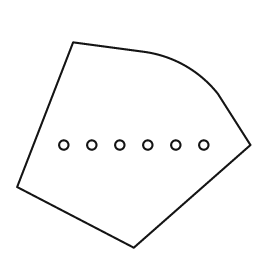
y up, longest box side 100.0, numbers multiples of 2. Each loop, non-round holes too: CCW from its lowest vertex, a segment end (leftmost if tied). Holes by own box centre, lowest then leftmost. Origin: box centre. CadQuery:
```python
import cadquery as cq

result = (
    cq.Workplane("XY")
    .moveTo(0.0, -44.0)
    .lineTo(50.0, 0.0)
    .lineTo(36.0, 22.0)
    .threePointArc((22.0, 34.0), (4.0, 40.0))
    .lineTo(-26.0, 44.0)
    .lineTo(-50.0, -18.0)
    .close()
    .moveTo(-30.0, 0.0)
    .circle(2.0)
    .moveTo(-18.0, 0.0)
    .circle(2.0)
    .moveTo(-6.0, 0.0)
    .circle(2.0)
    .moveTo(6.0, 0.0)
    .circle(2.0)
    .moveTo(18.0, 0.0)
    .circle(2.0)
    .moveTo(30.0, 0.0)
    .circle(2.0)
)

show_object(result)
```